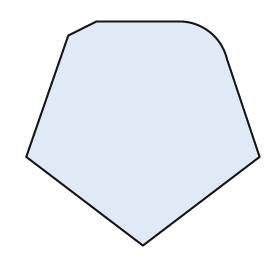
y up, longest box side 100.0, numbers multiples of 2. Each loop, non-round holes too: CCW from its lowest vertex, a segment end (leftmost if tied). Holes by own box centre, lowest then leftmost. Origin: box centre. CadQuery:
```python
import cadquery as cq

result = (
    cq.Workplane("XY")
    .moveTo(0.0, -48.0)
    .lineTo(50.0, -10.0)
    .lineTo(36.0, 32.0)
    .threePointArc((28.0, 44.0), (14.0, 48.0))
    .lineTo(-20.0, 48.0)
    .lineTo(-32.0, 42.0)
    .lineTo(-50.0, -10.0)
    .close()
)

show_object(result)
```